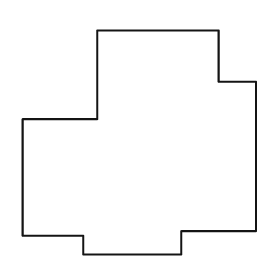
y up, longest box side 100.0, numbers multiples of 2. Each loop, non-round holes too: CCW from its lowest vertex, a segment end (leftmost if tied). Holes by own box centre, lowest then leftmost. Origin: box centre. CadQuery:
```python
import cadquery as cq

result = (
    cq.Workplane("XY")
    .moveTo(-24.0, -48.0)
    .lineTo(18.0, -48.0)
    .lineTo(18.0, -38.0)
    .lineTo(50.0, -38.0)
    .lineTo(50.0, 26.0)
    .lineTo(34.0, 26.0)
    .lineTo(34.0, 48.0)
    .lineTo(-18.0, 48.0)
    .lineTo(-18.0, 10.0)
    .lineTo(-50.0, 10.0)
    .lineTo(-50.0, -40.0)
    .lineTo(-24.0, -40.0)
    .close()
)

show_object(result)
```